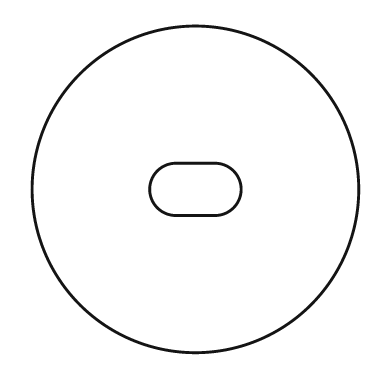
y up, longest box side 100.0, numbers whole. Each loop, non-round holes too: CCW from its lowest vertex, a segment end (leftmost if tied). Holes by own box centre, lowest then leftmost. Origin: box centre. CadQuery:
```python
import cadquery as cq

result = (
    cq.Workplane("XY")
    .moveTo(0.0, 0.0)
    .circle(50.0)
    .moveTo(-6.0, -8.0)
    .lineTo(6.0, -8.0)
    .threePointArc((14.0, 0.0), (6.0, 8.0))
    .lineTo(-6.0, 8.0)
    .threePointArc((-14.0, 0.0), (-6.0, -8.0))
    .close()
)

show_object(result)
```